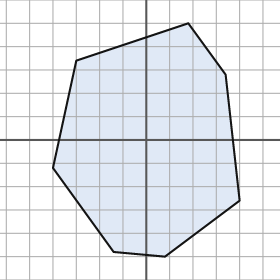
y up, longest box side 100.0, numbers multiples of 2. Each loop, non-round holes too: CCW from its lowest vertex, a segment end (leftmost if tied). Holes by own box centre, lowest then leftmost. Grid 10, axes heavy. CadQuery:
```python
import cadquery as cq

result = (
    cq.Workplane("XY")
    .moveTo(8.0, -50.0)
    .lineTo(40.0, -26.0)
    .lineTo(34.0, 28.0)
    .lineTo(18.0, 50.0)
    .lineTo(-30.0, 34.0)
    .lineTo(-40.0, -12.0)
    .lineTo(-14.0, -48.0)
    .close()
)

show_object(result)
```